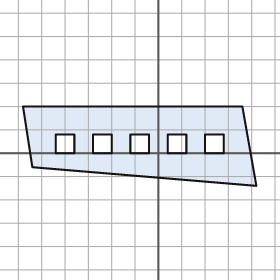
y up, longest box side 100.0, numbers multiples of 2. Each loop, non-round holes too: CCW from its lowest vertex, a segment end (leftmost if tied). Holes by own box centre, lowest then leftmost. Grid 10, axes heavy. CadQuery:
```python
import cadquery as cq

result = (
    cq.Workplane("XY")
    .moveTo(42.0, -14.0)
    .lineTo(36.0, 20.0)
    .lineTo(-58.0, 20.0)
    .lineTo(-54.0, -6.0)
    .close()
    .moveTo(-44.0, 0.0)
    .lineTo(-36.0, 0.0)
    .lineTo(-36.0, 8.0)
    .lineTo(-44.0, 8.0)
    .close()
    .moveTo(-28.0, 0.0)
    .lineTo(-20.0, 0.0)
    .lineTo(-20.0, 8.0)
    .lineTo(-28.0, 8.0)
    .close()
    .moveTo(-12.0, 0.0)
    .lineTo(-4.0, 0.0)
    .lineTo(-4.0, 8.0)
    .lineTo(-12.0, 8.0)
    .close()
    .moveTo(4.0, 0.0)
    .lineTo(12.0, 0.0)
    .lineTo(12.0, 8.0)
    .lineTo(4.0, 8.0)
    .close()
    .moveTo(20.0, 0.0)
    .lineTo(28.0, 0.0)
    .lineTo(28.0, 8.0)
    .lineTo(20.0, 8.0)
    .close()
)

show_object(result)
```